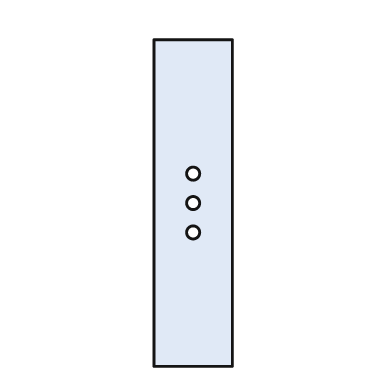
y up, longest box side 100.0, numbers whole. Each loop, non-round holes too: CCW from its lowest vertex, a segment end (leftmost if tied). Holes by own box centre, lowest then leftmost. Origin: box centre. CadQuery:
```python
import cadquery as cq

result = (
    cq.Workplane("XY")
    .moveTo(-12.0, -50.0)
    .lineTo(12.0, -50.0)
    .lineTo(12.0, 50.0)
    .lineTo(-12.0, 50.0)
    .close()
    .moveTo(0.0, -9.0)
    .circle(2.0)
    .moveTo(0.0, 0.0)
    .circle(2.0)
    .moveTo(0.0, 9.0)
    .circle(2.0)
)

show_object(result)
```